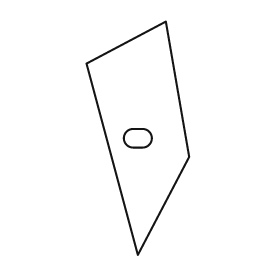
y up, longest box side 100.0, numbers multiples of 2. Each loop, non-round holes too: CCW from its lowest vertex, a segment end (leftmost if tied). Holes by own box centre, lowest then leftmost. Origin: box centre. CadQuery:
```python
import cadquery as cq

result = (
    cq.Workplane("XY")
    .moveTo(0.0, -50.0)
    .lineTo(22.0, -8.0)
    .lineTo(12.0, 50.0)
    .lineTo(-22.0, 32.0)
    .close()
    .moveTo(-2.0, -4.0)
    .lineTo(2.0, -4.0)
    .threePointArc((6.0, 0.0), (2.0, 4.0))
    .lineTo(-2.0, 4.0)
    .threePointArc((-6.0, 0.0), (-2.0, -4.0))
    .close()
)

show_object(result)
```